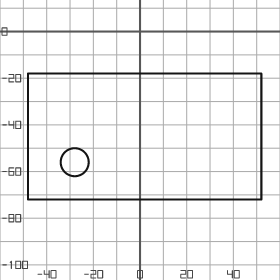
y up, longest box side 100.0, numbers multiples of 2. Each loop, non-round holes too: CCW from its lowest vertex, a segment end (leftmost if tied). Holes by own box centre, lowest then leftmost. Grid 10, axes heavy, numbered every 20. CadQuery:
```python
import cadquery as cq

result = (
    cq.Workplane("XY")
    .moveTo(-48.0, -72.0)
    .lineTo(52.0, -72.0)
    .lineTo(52.0, -18.0)
    .lineTo(-48.0, -18.0)
    .close()
    .moveTo(-28.0, -56.0)
    .circle(6.0)
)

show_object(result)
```